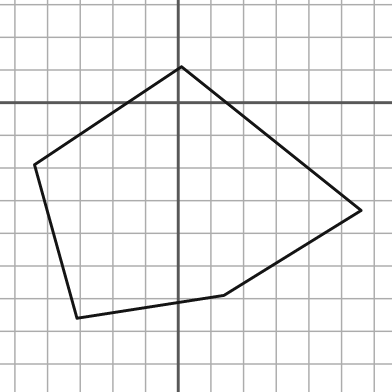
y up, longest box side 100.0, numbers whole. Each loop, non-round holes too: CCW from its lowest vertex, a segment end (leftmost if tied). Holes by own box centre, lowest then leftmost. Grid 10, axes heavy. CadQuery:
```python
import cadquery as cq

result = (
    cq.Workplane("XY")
    .moveTo(-31.0, -66.0)
    .lineTo(14.0, -59.0)
    .lineTo(56.0, -33.0)
    .lineTo(1.0, 11.0)
    .lineTo(-44.0, -19.0)
    .close()
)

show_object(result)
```